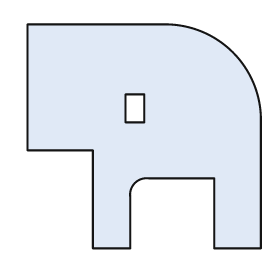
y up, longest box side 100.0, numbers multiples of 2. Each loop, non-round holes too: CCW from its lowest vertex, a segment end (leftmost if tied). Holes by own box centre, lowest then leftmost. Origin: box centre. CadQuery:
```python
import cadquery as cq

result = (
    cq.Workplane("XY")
    .moveTo(-22.0, -48.0)
    .lineTo(-6.0, -48.0)
    .lineTo(-6.0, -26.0)
    .threePointArc((-4.0, -20.0), (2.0, -18.0))
    .lineTo(30.0, -18.0)
    .lineTo(30.0, -48.0)
    .lineTo(50.0, -48.0)
    .lineTo(50.0, 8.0)
    .threePointArc((38.0, 36.0), (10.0, 48.0))
    .lineTo(-50.0, 48.0)
    .lineTo(-50.0, -6.0)
    .lineTo(-22.0, -6.0)
    .close()
    .moveTo(-8.0, 6.0)
    .lineTo(0.0, 6.0)
    .lineTo(0.0, 18.0)
    .lineTo(-8.0, 18.0)
    .close()
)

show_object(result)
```